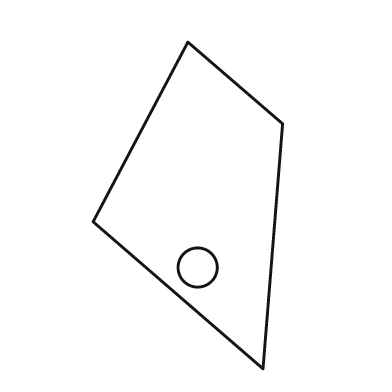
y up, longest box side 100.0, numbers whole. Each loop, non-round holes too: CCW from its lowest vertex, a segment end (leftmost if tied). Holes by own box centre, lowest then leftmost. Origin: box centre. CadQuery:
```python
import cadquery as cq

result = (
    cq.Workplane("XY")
    .moveTo(23.0, -50.0)
    .lineTo(29.0, 25.0)
    .lineTo(0.0, 50.0)
    .lineTo(-29.0, -5.0)
    .close()
    .moveTo(3.0, -19.0)
    .circle(6.0)
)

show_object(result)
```